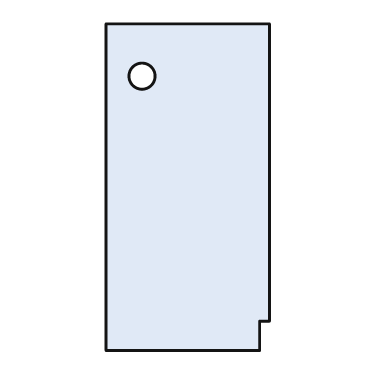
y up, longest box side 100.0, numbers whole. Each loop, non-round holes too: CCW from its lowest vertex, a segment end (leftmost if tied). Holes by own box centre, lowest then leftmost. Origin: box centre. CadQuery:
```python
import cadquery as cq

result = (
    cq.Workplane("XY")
    .moveTo(-25.0, -50.0)
    .lineTo(22.0, -50.0)
    .lineTo(22.0, -41.0)
    .lineTo(25.0, -41.0)
    .lineTo(25.0, 50.0)
    .lineTo(-25.0, 50.0)
    .close()
    .moveTo(-14.0, 34.0)
    .circle(4.0)
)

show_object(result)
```